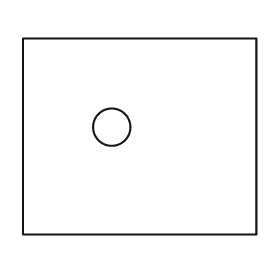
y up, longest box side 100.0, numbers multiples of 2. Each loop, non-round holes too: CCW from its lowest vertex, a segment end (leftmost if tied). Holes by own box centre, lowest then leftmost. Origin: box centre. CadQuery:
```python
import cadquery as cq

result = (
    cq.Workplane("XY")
    .moveTo(-50.0, -42.0)
    .lineTo(50.0, -42.0)
    .lineTo(50.0, 42.0)
    .lineTo(-50.0, 42.0)
    .close()
    .moveTo(-12.0, 4.0)
    .circle(8.0)
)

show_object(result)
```